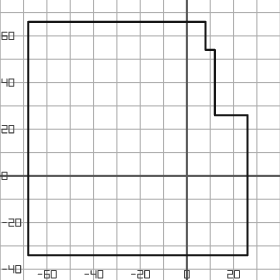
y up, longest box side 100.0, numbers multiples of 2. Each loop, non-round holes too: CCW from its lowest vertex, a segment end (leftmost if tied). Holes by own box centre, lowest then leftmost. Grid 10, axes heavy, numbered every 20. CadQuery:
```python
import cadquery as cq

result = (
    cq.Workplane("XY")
    .moveTo(-68.0, -34.0)
    .lineTo(26.0, -34.0)
    .lineTo(26.0, 26.0)
    .lineTo(12.0, 26.0)
    .lineTo(12.0, 54.0)
    .lineTo(8.0, 54.0)
    .lineTo(8.0, 66.0)
    .lineTo(-68.0, 66.0)
    .close()
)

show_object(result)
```